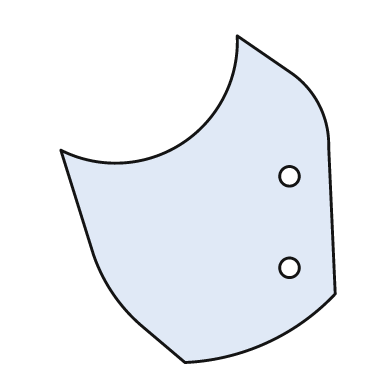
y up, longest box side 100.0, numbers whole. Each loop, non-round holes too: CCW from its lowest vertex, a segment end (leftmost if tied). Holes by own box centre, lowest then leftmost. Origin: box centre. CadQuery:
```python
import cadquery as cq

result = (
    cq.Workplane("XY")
    .moveTo(-4.0, -50.0)
    .threePointArc((21.0, -44.0), (42.0, -29.0))
    .lineTo(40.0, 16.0)
    .threePointArc((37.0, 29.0), (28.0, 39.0))
    .lineTo(12.0, 50.0)
    .threePointArc((-5.0, 17.0), (-42.0, 15.0))
    .lineTo(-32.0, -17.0)
    .threePointArc((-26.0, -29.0), (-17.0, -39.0))
    .close()
    .moveTo(28.0, -21.0)
    .circle(3.0)
    .moveTo(28.0, 7.0)
    .circle(3.0)
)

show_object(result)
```